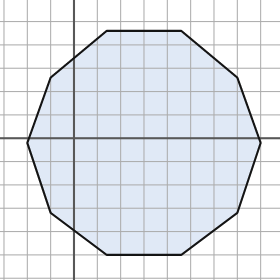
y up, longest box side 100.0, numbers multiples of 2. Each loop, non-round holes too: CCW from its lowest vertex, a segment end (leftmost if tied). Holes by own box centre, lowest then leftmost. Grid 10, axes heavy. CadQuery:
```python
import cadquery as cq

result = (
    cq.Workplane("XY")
    .moveTo(14.0, -50.0)
    .lineTo(46.0, -50.0)
    .lineTo(70.0, -32.0)
    .lineTo(80.0, -2.0)
    .lineTo(70.0, 26.0)
    .lineTo(46.0, 46.0)
    .lineTo(14.0, 46.0)
    .lineTo(-10.0, 26.0)
    .lineTo(-20.0, -2.0)
    .lineTo(-10.0, -32.0)
    .close()
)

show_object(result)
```